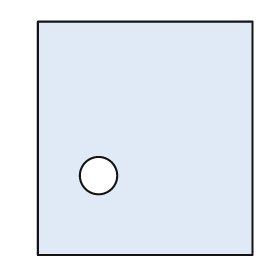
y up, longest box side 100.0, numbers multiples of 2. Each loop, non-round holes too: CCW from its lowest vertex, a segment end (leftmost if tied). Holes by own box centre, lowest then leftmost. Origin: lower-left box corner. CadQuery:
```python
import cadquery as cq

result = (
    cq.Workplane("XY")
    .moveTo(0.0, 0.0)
    .lineTo(92.0, 0.0)
    .lineTo(92.0, 100.0)
    .lineTo(0.0, 100.0)
    .close()
    .moveTo(26.0, 34.0)
    .circle(8.0)
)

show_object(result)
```